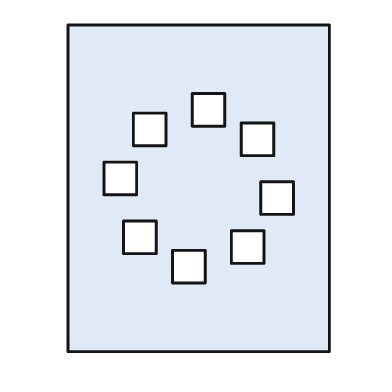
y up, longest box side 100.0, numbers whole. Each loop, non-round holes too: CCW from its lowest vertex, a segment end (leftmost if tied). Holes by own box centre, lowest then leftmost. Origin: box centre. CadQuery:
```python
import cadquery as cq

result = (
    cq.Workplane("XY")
    .moveTo(-40.0, -50.0)
    .lineTo(40.0, -50.0)
    .lineTo(40.0, 50.0)
    .lineTo(-40.0, 50.0)
    .close()
    .moveTo(-8.0, -29.0)
    .lineTo(2.0, -29.0)
    .lineTo(2.0, -19.0)
    .lineTo(-8.0, -19.0)
    .close()
    .moveTo(10.0, -23.0)
    .lineTo(20.0, -23.0)
    .lineTo(20.0, -13.0)
    .lineTo(10.0, -13.0)
    .close()
    .moveTo(-23.0, -20.0)
    .lineTo(-13.0, -20.0)
    .lineTo(-13.0, -10.0)
    .lineTo(-23.0, -10.0)
    .close()
    .moveTo(19.0, -8.0)
    .lineTo(29.0, -8.0)
    .lineTo(29.0, 2.0)
    .lineTo(19.0, 2.0)
    .close()
    .moveTo(-29.0, -2.0)
    .lineTo(-19.0, -2.0)
    .lineTo(-19.0, 8.0)
    .lineTo(-29.0, 8.0)
    .close()
    .moveTo(13.0, 10.0)
    .lineTo(23.0, 10.0)
    .lineTo(23.0, 20.0)
    .lineTo(13.0, 20.0)
    .close()
    .moveTo(-20.0, 13.0)
    .lineTo(-10.0, 13.0)
    .lineTo(-10.0, 23.0)
    .lineTo(-20.0, 23.0)
    .close()
    .moveTo(-2.0, 19.0)
    .lineTo(8.0, 19.0)
    .lineTo(8.0, 29.0)
    .lineTo(-2.0, 29.0)
    .close()
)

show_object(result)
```